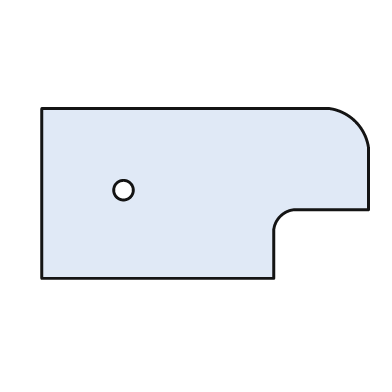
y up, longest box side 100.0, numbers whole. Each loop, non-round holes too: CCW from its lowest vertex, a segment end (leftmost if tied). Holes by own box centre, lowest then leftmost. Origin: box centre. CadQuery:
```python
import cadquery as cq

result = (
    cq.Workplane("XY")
    .moveTo(-50.0, -26.0)
    .lineTo(21.0, -26.0)
    .lineTo(21.0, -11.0)
    .threePointArc((23.0, -7.0), (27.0, -5.0))
    .lineTo(50.0, -5.0)
    .lineTo(50.0, 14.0)
    .threePointArc((46.0, 22.0), (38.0, 26.0))
    .lineTo(-50.0, 26.0)
    .close()
    .moveTo(-25.0, 1.0)
    .circle(3.0)
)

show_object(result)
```